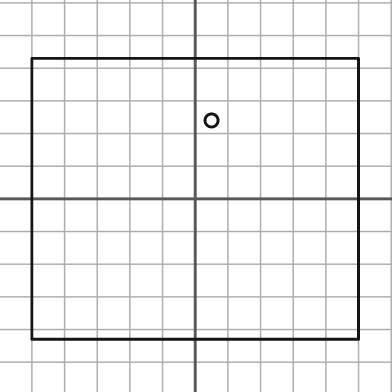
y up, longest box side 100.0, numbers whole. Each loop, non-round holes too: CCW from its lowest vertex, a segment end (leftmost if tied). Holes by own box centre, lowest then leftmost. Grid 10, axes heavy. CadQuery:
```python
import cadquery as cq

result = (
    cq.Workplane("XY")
    .moveTo(-50.0, -43.0)
    .lineTo(50.0, -43.0)
    .lineTo(50.0, 43.0)
    .lineTo(-50.0, 43.0)
    .close()
    .moveTo(5.0, 24.0)
    .circle(2.0)
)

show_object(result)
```